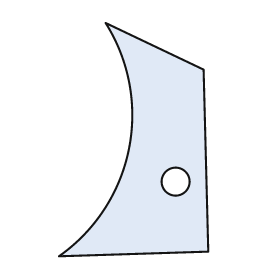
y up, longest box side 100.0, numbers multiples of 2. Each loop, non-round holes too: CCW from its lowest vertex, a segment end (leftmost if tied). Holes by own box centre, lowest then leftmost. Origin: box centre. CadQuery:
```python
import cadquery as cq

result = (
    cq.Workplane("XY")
    .moveTo(-32.0, -50.0)
    .lineTo(32.0, -48.0)
    .lineTo(30.0, 30.0)
    .lineTo(-12.0, 50.0)
    .threePointArc((-2.0, -4.0), (-32.0, -50.0))
    .close()
    .moveTo(18.0, -18.0)
    .circle(6.0)
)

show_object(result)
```